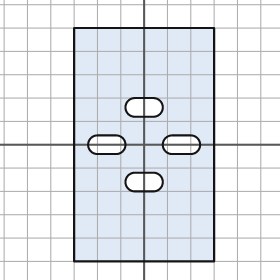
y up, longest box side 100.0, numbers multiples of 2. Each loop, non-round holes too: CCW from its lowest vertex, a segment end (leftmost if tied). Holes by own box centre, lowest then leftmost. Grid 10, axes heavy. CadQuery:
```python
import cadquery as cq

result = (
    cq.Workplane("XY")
    .moveTo(-30.0, -50.0)
    .lineTo(30.0, -50.0)
    .lineTo(30.0, 50.0)
    .lineTo(-30.0, 50.0)
    .close()
    .moveTo(-4.0, -20.0)
    .lineTo(4.0, -20.0)
    .threePointArc((8.0, -16.0), (4.0, -12.0))
    .lineTo(-4.0, -12.0)
    .threePointArc((-8.0, -16.0), (-4.0, -20.0))
    .close()
    .moveTo(-20.0, -4.0)
    .lineTo(-12.0, -4.0)
    .threePointArc((-8.0, 0.0), (-12.0, 4.0))
    .lineTo(-20.0, 4.0)
    .threePointArc((-24.0, 0.0), (-20.0, -4.0))
    .close()
    .moveTo(12.0, -4.0)
    .lineTo(20.0, -4.0)
    .threePointArc((24.0, 0.0), (20.0, 4.0))
    .lineTo(12.0, 4.0)
    .threePointArc((8.0, 0.0), (12.0, -4.0))
    .close()
    .moveTo(-4.0, 12.0)
    .lineTo(4.0, 12.0)
    .threePointArc((8.0, 16.0), (4.0, 20.0))
    .lineTo(-4.0, 20.0)
    .threePointArc((-8.0, 16.0), (-4.0, 12.0))
    .close()
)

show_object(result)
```